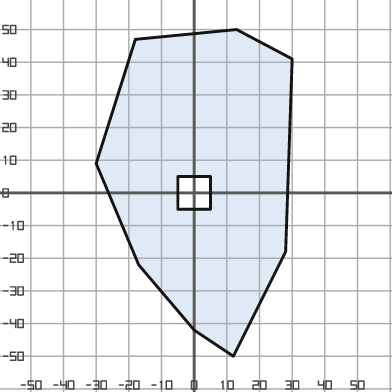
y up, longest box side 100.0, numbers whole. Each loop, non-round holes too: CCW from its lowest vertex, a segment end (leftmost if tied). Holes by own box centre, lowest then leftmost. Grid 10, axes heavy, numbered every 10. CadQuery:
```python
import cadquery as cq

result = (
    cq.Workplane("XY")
    .moveTo(12.0, -50.0)
    .lineTo(28.0, -18.0)
    .lineTo(30.0, 41.0)
    .lineTo(13.0, 50.0)
    .lineTo(-18.0, 47.0)
    .lineTo(-30.0, 9.0)
    .lineTo(-17.0, -22.0)
    .lineTo(0.0, -42.0)
    .close()
    .moveTo(-5.0, -5.0)
    .lineTo(5.0, -5.0)
    .lineTo(5.0, 5.0)
    .lineTo(-5.0, 5.0)
    .close()
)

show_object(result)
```